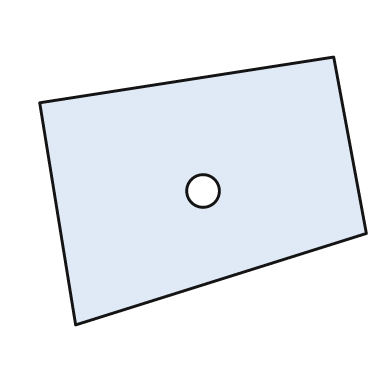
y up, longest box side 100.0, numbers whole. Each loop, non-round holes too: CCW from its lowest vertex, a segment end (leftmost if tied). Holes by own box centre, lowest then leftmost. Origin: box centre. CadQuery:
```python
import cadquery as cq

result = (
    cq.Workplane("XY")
    .moveTo(-39.0, -41.0)
    .lineTo(50.0, -13.0)
    .lineTo(40.0, 41.0)
    .lineTo(-50.0, 27.0)
    .close()
    .moveTo(0.0, 0.0)
    .circle(5.0)
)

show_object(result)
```